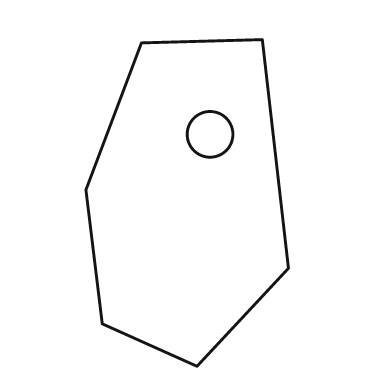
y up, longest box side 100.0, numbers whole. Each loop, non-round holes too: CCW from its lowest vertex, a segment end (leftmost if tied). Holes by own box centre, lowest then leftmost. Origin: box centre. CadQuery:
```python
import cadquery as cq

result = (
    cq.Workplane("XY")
    .moveTo(3.0, -50.0)
    .lineTo(31.0, -20.0)
    .lineTo(23.0, 50.0)
    .lineTo(-14.0, 49.0)
    .lineTo(-31.0, 4.0)
    .lineTo(-26.0, -37.0)
    .close()
    .moveTo(7.0, 21.0)
    .circle(7.0)
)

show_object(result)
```